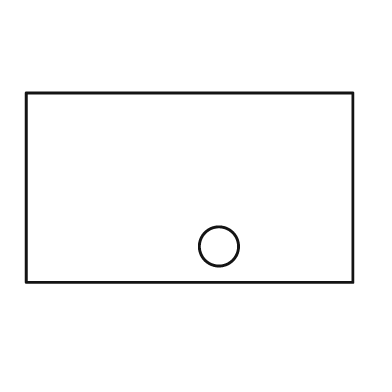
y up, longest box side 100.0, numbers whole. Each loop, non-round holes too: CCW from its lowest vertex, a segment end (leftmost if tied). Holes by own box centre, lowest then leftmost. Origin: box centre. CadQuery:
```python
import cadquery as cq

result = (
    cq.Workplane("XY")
    .moveTo(-50.0, -29.0)
    .lineTo(50.0, -29.0)
    .lineTo(50.0, 29.0)
    .lineTo(-50.0, 29.0)
    .close()
    .moveTo(9.0, -18.0)
    .circle(6.0)
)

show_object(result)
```